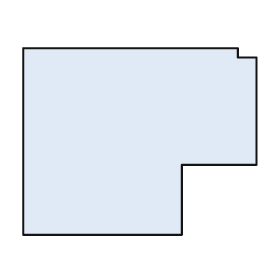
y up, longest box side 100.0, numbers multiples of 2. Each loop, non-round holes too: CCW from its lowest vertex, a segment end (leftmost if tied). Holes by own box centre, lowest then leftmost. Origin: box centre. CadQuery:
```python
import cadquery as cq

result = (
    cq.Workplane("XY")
    .moveTo(-50.0, -40.0)
    .lineTo(18.0, -40.0)
    .lineTo(18.0, -10.0)
    .lineTo(50.0, -10.0)
    .lineTo(50.0, 36.0)
    .lineTo(42.0, 36.0)
    .lineTo(42.0, 40.0)
    .lineTo(-50.0, 40.0)
    .close()
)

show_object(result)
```